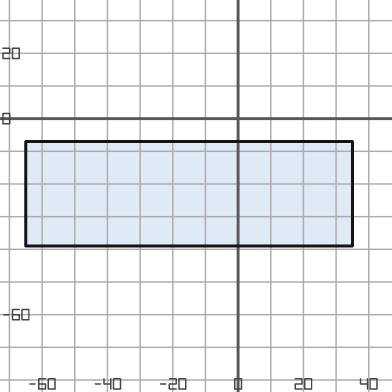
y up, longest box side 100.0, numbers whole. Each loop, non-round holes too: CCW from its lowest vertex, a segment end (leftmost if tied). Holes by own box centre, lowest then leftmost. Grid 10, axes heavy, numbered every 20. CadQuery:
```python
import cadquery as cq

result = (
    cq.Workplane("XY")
    .moveTo(-65.0, -39.0)
    .lineTo(35.0, -39.0)
    .lineTo(35.0, -7.0)
    .lineTo(-65.0, -7.0)
    .close()
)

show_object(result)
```